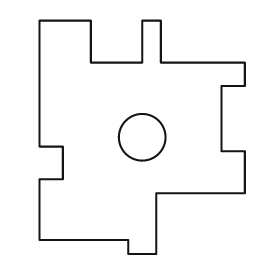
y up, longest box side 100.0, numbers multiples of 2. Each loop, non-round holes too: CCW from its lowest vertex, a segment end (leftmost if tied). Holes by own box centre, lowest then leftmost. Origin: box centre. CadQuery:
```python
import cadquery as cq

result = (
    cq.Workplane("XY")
    .moveTo(-6.0, -50.0)
    .lineTo(6.0, -50.0)
    .lineTo(6.0, -24.0)
    .lineTo(44.0, -24.0)
    .lineTo(44.0, -6.0)
    .lineTo(34.0, -6.0)
    .lineTo(34.0, 22.0)
    .lineTo(44.0, 22.0)
    .lineTo(44.0, 32.0)
    .lineTo(8.0, 32.0)
    .lineTo(8.0, 50.0)
    .lineTo(0.0, 50.0)
    .lineTo(0.0, 32.0)
    .lineTo(-22.0, 32.0)
    .lineTo(-22.0, 50.0)
    .lineTo(-44.0, 50.0)
    .lineTo(-44.0, -4.0)
    .lineTo(-34.0, -4.0)
    .lineTo(-34.0, -18.0)
    .lineTo(-44.0, -18.0)
    .lineTo(-44.0, -44.0)
    .lineTo(-6.0, -44.0)
    .close()
    .moveTo(0.0, 0.0)
    .circle(10.0)
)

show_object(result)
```